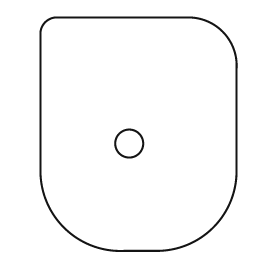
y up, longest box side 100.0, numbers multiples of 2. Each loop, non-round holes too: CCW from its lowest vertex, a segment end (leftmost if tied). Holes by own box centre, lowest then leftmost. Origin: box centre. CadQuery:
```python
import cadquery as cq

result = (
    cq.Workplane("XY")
    .moveTo(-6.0, -50.0)
    .lineTo(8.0, -50.0)
    .threePointArc((32.0, -40.0), (42.0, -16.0))
    .lineTo(42.0, 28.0)
    .threePointArc((36.0, 44.0), (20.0, 50.0))
    .lineTo(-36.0, 50.0)
    .threePointArc((-40.0, 48.0), (-42.0, 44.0))
    .lineTo(-42.0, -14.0)
    .threePointArc((-32.0, -40.0), (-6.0, -50.0))
    .close()
    .moveTo(-4.0, -4.0)
    .circle(6.0)
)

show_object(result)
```